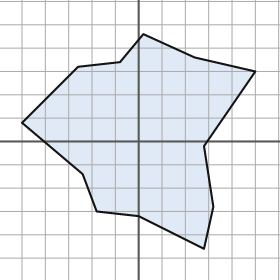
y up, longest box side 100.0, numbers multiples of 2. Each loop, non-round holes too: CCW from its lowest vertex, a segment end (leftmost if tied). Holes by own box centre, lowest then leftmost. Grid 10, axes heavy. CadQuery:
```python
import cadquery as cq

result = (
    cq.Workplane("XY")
    .moveTo(28.0, -46.0)
    .lineTo(32.0, -28.0)
    .lineTo(28.0, -2.0)
    .lineTo(50.0, 30.0)
    .lineTo(24.0, 36.0)
    .lineTo(2.0, 46.0)
    .lineTo(-8.0, 34.0)
    .lineTo(-26.0, 32.0)
    .lineTo(-50.0, 8.0)
    .lineTo(-24.0, -14.0)
    .lineTo(-18.0, -30.0)
    .lineTo(0.0, -32.0)
    .close()
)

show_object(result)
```